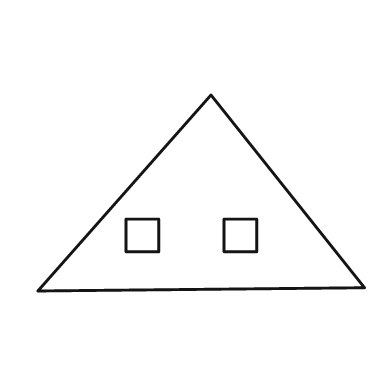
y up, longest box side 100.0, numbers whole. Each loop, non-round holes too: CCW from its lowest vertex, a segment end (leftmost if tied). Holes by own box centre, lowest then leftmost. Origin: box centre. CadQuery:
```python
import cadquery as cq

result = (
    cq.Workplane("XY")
    .moveTo(-50.0, -30.0)
    .lineTo(50.0, -29.0)
    .lineTo(3.0, 30.0)
    .close()
    .moveTo(-23.0, -18.0)
    .lineTo(-13.0, -18.0)
    .lineTo(-13.0, -8.0)
    .lineTo(-23.0, -8.0)
    .close()
    .moveTo(7.0, -18.0)
    .lineTo(17.0, -18.0)
    .lineTo(17.0, -8.0)
    .lineTo(7.0, -8.0)
    .close()
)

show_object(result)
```